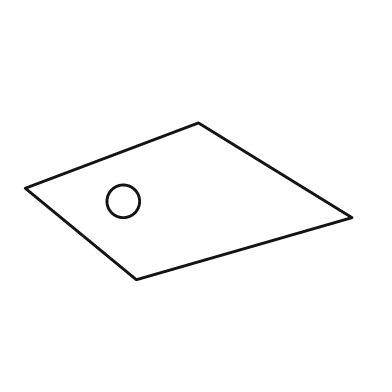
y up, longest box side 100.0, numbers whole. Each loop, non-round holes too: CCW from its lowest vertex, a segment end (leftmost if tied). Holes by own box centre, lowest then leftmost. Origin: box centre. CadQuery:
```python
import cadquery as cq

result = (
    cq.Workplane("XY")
    .moveTo(-16.0, -24.0)
    .lineTo(50.0, -5.0)
    .lineTo(3.0, 24.0)
    .lineTo(-50.0, 4.0)
    .close()
    .moveTo(-20.0, 0.0)
    .circle(5.0)
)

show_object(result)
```